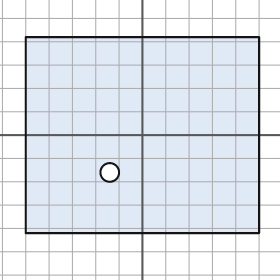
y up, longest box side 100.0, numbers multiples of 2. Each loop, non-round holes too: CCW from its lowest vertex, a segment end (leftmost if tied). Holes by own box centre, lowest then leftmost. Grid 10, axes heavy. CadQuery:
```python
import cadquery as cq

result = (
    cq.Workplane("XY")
    .moveTo(-50.0, -42.0)
    .lineTo(50.0, -42.0)
    .lineTo(50.0, 42.0)
    .lineTo(-50.0, 42.0)
    .close()
    .moveTo(-14.0, -16.0)
    .circle(4.0)
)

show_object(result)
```